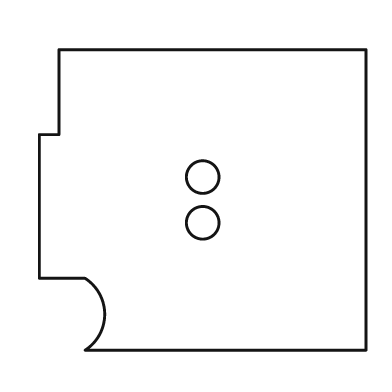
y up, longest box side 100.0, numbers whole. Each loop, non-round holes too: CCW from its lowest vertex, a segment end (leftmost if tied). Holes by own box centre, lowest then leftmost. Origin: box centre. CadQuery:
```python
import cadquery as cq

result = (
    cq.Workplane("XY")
    .moveTo(-36.0, -46.0)
    .lineTo(50.0, -46.0)
    .lineTo(50.0, 46.0)
    .lineTo(-44.0, 46.0)
    .lineTo(-44.0, 20.0)
    .lineTo(-50.0, 20.0)
    .lineTo(-50.0, -24.0)
    .lineTo(-36.0, -24.0)
    .threePointArc((-30.0, -35.0), (-36.0, -46.0))
    .close()
    .moveTo(0.0, -7.0)
    .circle(5.0)
    .moveTo(0.0, 7.0)
    .circle(5.0)
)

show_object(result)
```